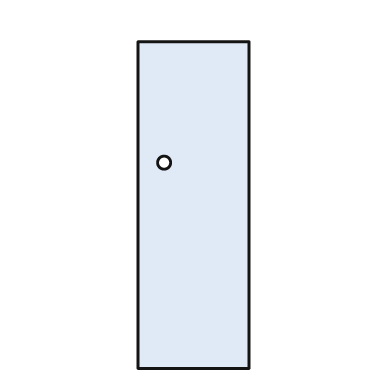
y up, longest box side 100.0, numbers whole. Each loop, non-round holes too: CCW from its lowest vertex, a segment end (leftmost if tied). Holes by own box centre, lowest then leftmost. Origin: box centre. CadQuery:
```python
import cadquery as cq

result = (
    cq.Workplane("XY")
    .moveTo(-17.0, -50.0)
    .lineTo(17.0, -50.0)
    .lineTo(17.0, 50.0)
    .lineTo(-17.0, 50.0)
    .close()
    .moveTo(-9.0, 13.0)
    .circle(2.0)
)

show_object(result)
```